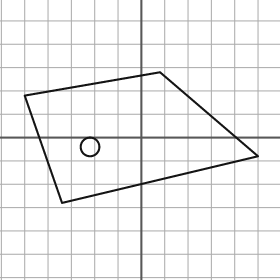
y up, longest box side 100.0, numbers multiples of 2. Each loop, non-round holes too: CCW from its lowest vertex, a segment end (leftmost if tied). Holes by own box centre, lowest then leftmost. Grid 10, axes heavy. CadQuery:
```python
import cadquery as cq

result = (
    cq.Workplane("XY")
    .moveTo(-34.0, -28.0)
    .lineTo(50.0, -8.0)
    .lineTo(8.0, 28.0)
    .lineTo(-50.0, 18.0)
    .close()
    .moveTo(-22.0, -4.0)
    .circle(4.0)
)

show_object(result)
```